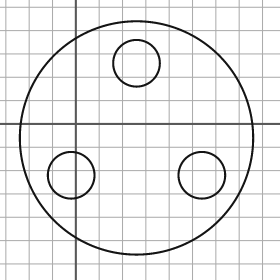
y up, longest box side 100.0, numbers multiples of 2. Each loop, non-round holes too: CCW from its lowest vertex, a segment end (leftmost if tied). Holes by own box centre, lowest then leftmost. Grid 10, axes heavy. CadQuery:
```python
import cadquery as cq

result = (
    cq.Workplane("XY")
    .moveTo(26.0, -6.0)
    .circle(50.0)
    .moveTo(-2.0, -22.0)
    .circle(10.0)
    .moveTo(54.0, -22.0)
    .circle(10.0)
    .moveTo(26.0, 26.0)
    .circle(10.0)
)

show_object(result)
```